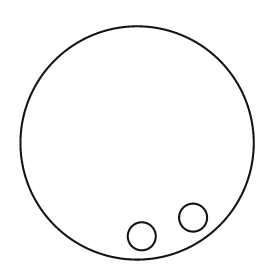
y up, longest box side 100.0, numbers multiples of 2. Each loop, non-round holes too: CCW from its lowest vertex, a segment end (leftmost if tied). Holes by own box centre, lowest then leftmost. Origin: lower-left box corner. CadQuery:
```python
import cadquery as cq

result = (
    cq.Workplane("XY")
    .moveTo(50.0, 50.0)
    .circle(50.0)
    .moveTo(52.0, 10.0)
    .circle(6.0)
    .moveTo(74.0, 18.0)
    .circle(6.0)
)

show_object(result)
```